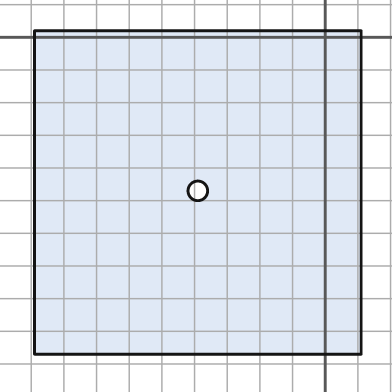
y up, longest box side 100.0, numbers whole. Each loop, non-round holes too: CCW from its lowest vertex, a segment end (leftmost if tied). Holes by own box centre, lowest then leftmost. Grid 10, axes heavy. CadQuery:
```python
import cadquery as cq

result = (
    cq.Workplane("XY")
    .moveTo(-89.0, -97.0)
    .lineTo(11.0, -97.0)
    .lineTo(11.0, 2.0)
    .lineTo(-89.0, 2.0)
    .close()
    .moveTo(-39.0, -47.0)
    .circle(3.0)
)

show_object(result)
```